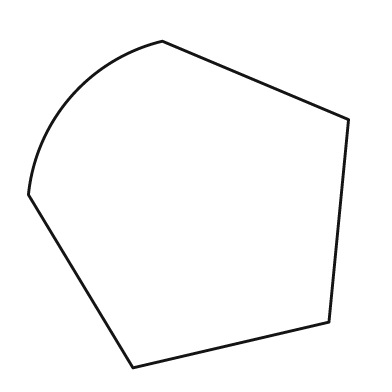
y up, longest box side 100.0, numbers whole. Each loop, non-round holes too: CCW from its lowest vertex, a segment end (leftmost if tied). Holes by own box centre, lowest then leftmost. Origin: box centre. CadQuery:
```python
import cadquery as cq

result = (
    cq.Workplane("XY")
    .moveTo(-17.0, -50.0)
    .lineTo(43.0, -36.0)
    .lineTo(49.0, 26.0)
    .lineTo(-8.0, 50.0)
    .threePointArc((-36.0, 33.0), (-49.0, 3.0))
    .close()
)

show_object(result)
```